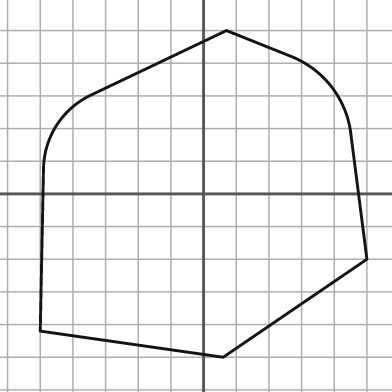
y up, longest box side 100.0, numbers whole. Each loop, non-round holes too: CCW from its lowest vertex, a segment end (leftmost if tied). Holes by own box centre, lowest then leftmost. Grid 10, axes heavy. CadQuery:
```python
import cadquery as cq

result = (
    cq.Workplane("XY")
    .moveTo(6.0, -50.0)
    .lineTo(50.0, -20.0)
    .lineTo(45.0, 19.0)
    .threePointArc((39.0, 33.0), (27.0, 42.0))
    .lineTo(7.0, 50.0)
    .lineTo(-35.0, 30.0)
    .threePointArc((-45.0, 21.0), (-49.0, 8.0))
    .lineTo(-50.0, -42.0)
    .close()
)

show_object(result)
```